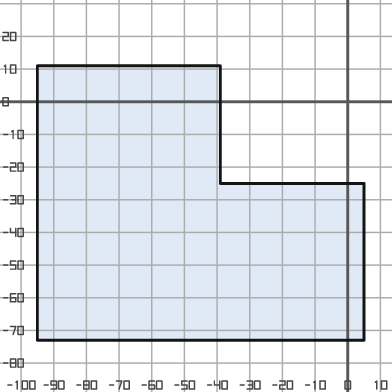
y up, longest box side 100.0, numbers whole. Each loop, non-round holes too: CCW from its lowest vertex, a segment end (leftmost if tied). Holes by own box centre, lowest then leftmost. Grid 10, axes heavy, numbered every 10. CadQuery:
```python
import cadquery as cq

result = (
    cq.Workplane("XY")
    .moveTo(-95.0, -73.0)
    .lineTo(5.0, -73.0)
    .lineTo(5.0, -25.0)
    .lineTo(-39.0, -25.0)
    .lineTo(-39.0, 11.0)
    .lineTo(-95.0, 11.0)
    .close()
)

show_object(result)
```